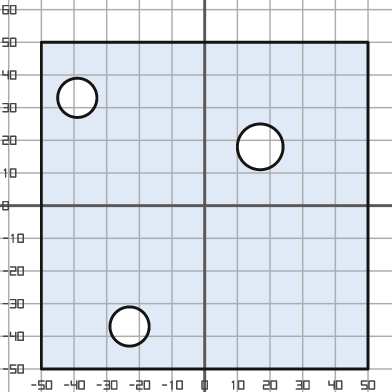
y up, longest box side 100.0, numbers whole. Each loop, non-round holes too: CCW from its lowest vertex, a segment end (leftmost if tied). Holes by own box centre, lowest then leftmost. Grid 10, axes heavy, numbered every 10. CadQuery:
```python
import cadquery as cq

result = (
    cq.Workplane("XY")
    .moveTo(-50.0, -50.0)
    .lineTo(50.0, -50.0)
    .lineTo(50.0, 50.0)
    .lineTo(-50.0, 50.0)
    .close()
    .moveTo(-23.0, -37.0)
    .circle(6.0)
    .moveTo(17.0, 18.0)
    .circle(7.0)
    .moveTo(-39.0, 33.0)
    .circle(6.0)
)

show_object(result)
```